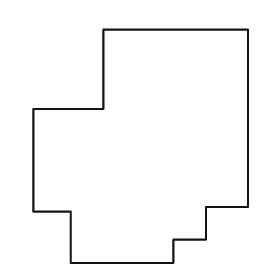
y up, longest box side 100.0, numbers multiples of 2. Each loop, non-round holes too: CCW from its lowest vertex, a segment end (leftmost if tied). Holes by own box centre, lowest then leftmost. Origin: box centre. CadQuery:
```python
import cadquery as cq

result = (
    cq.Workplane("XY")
    .moveTo(-30.0, -50.0)
    .lineTo(14.0, -50.0)
    .lineTo(14.0, -40.0)
    .lineTo(28.0, -40.0)
    .lineTo(28.0, -26.0)
    .lineTo(46.0, -26.0)
    .lineTo(46.0, 50.0)
    .lineTo(-16.0, 50.0)
    .lineTo(-16.0, 16.0)
    .lineTo(-46.0, 16.0)
    .lineTo(-46.0, -28.0)
    .lineTo(-30.0, -28.0)
    .close()
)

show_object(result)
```